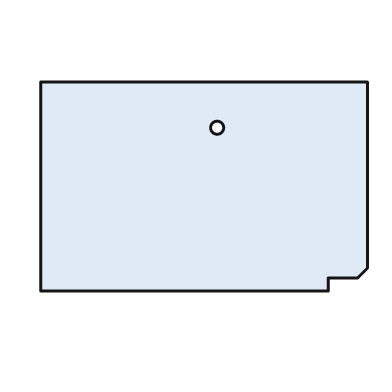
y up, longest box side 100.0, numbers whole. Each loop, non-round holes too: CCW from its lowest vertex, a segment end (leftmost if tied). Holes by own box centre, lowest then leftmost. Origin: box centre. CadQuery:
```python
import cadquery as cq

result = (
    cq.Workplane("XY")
    .moveTo(-50.0, -32.0)
    .lineTo(38.0, -32.0)
    .lineTo(38.0, -28.0)
    .lineTo(47.0, -28.0)
    .lineTo(50.0, -25.0)
    .lineTo(50.0, 32.0)
    .lineTo(-50.0, 32.0)
    .close()
    .moveTo(4.0, 18.0)
    .circle(2.0)
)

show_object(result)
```